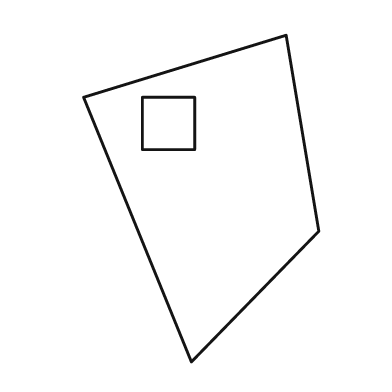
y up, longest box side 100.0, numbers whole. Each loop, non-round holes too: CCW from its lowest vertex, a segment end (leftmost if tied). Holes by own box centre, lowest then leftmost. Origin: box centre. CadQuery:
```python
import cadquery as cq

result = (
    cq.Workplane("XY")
    .moveTo(-3.0, -50.0)
    .lineTo(36.0, -10.0)
    .lineTo(26.0, 50.0)
    .lineTo(-36.0, 31.0)
    .close()
    .moveTo(-18.0, 15.0)
    .lineTo(-2.0, 15.0)
    .lineTo(-2.0, 31.0)
    .lineTo(-18.0, 31.0)
    .close()
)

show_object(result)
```